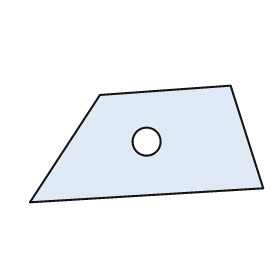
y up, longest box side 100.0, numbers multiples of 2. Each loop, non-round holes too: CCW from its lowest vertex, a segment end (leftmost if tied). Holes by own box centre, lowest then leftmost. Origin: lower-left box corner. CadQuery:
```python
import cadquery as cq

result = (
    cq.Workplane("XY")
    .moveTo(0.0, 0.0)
    .lineTo(100.0, 6.0)
    .lineTo(86.0, 50.0)
    .lineTo(30.0, 46.0)
    .close()
    .moveTo(50.0, 26.0)
    .circle(6.0)
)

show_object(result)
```